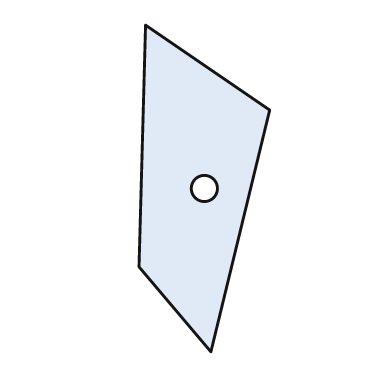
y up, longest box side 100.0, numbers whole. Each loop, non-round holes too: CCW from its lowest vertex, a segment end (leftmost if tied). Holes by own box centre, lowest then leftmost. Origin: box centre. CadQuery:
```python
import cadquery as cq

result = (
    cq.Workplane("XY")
    .moveTo(2.0, -50.0)
    .lineTo(20.0, 24.0)
    .lineTo(-18.0, 50.0)
    .lineTo(-20.0, -24.0)
    .close()
    .moveTo(0.0, 0.0)
    .circle(4.0)
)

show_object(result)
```